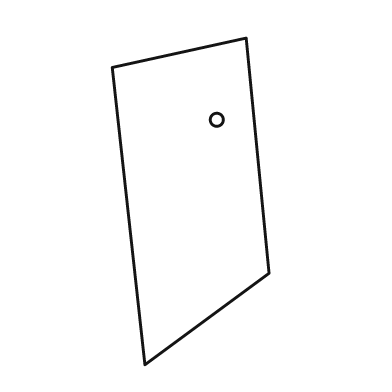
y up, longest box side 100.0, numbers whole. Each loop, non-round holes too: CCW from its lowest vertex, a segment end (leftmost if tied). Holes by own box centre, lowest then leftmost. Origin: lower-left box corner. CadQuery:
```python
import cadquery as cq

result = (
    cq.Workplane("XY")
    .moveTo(10.0, 0.0)
    .lineTo(48.0, 28.0)
    .lineTo(41.0, 100.0)
    .lineTo(0.0, 91.0)
    .close()
    .moveTo(32.0, 75.0)
    .circle(2.0)
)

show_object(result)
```